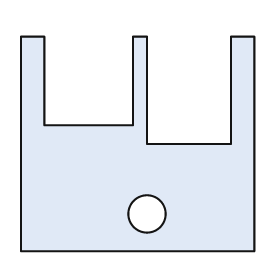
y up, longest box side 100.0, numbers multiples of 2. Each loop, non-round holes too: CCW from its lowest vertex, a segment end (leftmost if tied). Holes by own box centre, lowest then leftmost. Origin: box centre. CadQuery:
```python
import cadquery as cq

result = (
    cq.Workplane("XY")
    .moveTo(-50.0, -46.0)
    .lineTo(50.0, -46.0)
    .lineTo(50.0, 46.0)
    .lineTo(40.0, 46.0)
    .lineTo(40.0, 0.0)
    .lineTo(4.0, 0.0)
    .lineTo(4.0, 46.0)
    .lineTo(-2.0, 46.0)
    .lineTo(-2.0, 8.0)
    .lineTo(-40.0, 8.0)
    .lineTo(-40.0, 46.0)
    .lineTo(-50.0, 46.0)
    .close()
    .moveTo(4.0, -30.0)
    .circle(8.0)
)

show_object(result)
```